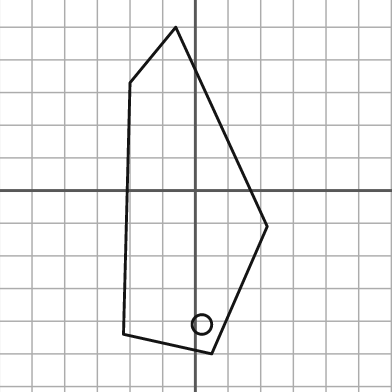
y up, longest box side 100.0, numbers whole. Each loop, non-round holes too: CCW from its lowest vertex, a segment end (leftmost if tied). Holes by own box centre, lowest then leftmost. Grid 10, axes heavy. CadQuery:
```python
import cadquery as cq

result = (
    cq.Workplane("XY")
    .moveTo(5.0, -50.0)
    .lineTo(22.0, -11.0)
    .lineTo(-6.0, 50.0)
    .lineTo(-20.0, 33.0)
    .lineTo(-22.0, -44.0)
    .close()
    .moveTo(2.0, -41.0)
    .circle(3.0)
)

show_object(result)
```